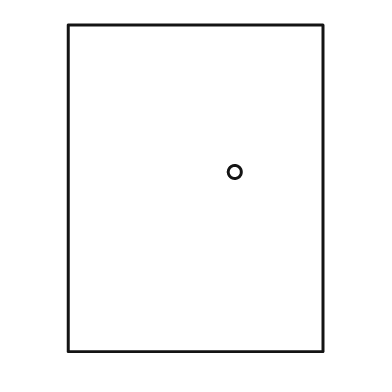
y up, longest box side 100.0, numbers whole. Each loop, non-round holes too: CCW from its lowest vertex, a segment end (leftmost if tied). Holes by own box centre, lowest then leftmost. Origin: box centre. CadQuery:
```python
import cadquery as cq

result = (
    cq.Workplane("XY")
    .moveTo(-39.0, -50.0)
    .lineTo(39.0, -50.0)
    .lineTo(39.0, 50.0)
    .lineTo(-39.0, 50.0)
    .close()
    .moveTo(12.0, 5.0)
    .circle(2.0)
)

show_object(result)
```